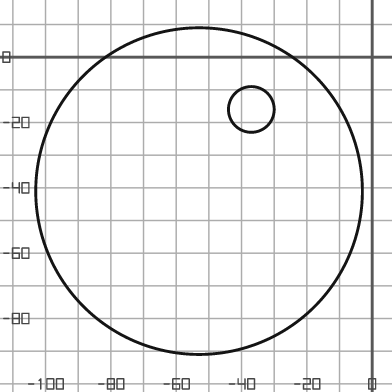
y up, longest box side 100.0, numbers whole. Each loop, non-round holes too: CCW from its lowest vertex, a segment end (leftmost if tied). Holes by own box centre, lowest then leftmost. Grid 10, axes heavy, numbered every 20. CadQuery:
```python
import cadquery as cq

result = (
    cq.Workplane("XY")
    .moveTo(-53.0, -41.0)
    .circle(50.0)
    .moveTo(-37.0, -16.0)
    .circle(7.0)
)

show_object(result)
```